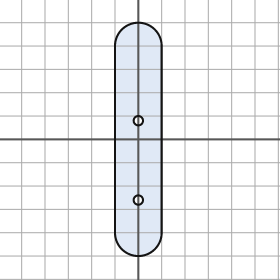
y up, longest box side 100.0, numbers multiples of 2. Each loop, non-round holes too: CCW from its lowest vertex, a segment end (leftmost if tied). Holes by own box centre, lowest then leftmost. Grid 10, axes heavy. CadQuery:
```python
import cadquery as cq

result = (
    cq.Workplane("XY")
    .moveTo(-10.0, -40.0)
    .threePointArc((0.0, -50.0), (10.0, -40.0))
    .lineTo(10.0, 40.0)
    .threePointArc((0.0, 50.0), (-10.0, 40.0))
    .close()
    .moveTo(0.0, -26.0)
    .circle(2.0)
    .moveTo(0.0, 8.0)
    .circle(2.0)
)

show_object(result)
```